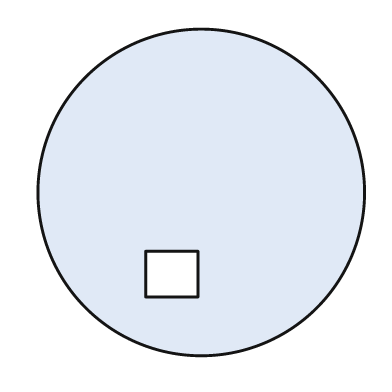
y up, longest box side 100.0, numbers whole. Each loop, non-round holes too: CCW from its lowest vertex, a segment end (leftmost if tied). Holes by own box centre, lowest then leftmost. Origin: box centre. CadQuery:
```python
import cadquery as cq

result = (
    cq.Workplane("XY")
    .moveTo(0.0, 0.0)
    .circle(50.0)
    .moveTo(-17.0, -32.0)
    .lineTo(-1.0, -32.0)
    .lineTo(-1.0, -18.0)
    .lineTo(-17.0, -18.0)
    .close()
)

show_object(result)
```